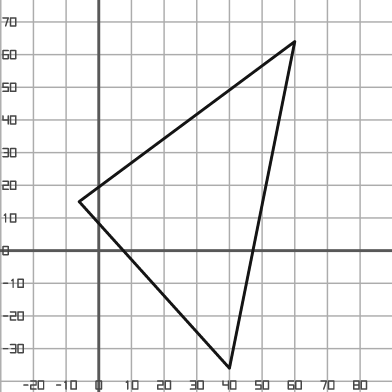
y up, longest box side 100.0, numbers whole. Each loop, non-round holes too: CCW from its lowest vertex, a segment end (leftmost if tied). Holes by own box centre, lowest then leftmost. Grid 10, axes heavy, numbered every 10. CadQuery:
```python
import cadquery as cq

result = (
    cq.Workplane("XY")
    .moveTo(40.0, -36.0)
    .lineTo(60.0, 64.0)
    .lineTo(-6.0, 15.0)
    .close()
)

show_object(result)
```